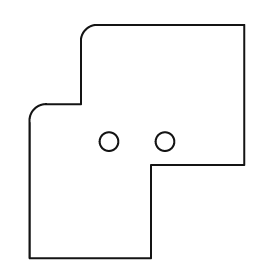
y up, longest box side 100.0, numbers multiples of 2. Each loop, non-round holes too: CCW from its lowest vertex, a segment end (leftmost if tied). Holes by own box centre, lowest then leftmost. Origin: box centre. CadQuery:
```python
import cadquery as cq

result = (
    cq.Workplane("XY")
    .moveTo(-46.0, -50.0)
    .lineTo(6.0, -50.0)
    .lineTo(6.0, -10.0)
    .lineTo(46.0, -10.0)
    .lineTo(46.0, 50.0)
    .lineTo(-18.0, 50.0)
    .threePointArc((-22.0, 48.0), (-24.0, 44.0))
    .lineTo(-24.0, 16.0)
    .lineTo(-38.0, 16.0)
    .threePointArc((-44.0, 14.0), (-46.0, 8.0))
    .close()
    .moveTo(-12.0, 0.0)
    .circle(4.0)
    .moveTo(12.0, 0.0)
    .circle(4.0)
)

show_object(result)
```